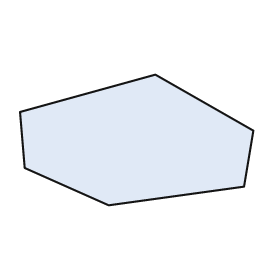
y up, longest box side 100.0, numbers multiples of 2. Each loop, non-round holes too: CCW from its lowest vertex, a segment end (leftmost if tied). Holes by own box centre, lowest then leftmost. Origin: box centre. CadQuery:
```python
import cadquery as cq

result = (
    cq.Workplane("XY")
    .moveTo(-12.0, -28.0)
    .lineTo(46.0, -20.0)
    .lineTo(50.0, 4.0)
    .lineTo(8.0, 28.0)
    .lineTo(-50.0, 12.0)
    .lineTo(-48.0, -12.0)
    .close()
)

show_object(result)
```